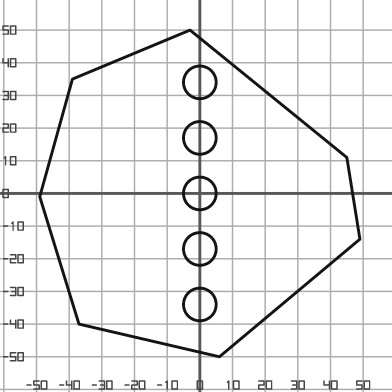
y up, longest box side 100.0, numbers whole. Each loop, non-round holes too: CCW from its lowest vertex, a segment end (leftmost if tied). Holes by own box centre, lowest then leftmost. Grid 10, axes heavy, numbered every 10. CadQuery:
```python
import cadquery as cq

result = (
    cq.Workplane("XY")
    .moveTo(6.0, -50.0)
    .lineTo(49.0, -14.0)
    .lineTo(45.0, 11.0)
    .lineTo(-3.0, 50.0)
    .lineTo(-39.0, 35.0)
    .lineTo(-49.0, -1.0)
    .lineTo(-37.0, -40.0)
    .close()
    .moveTo(0.0, -34.0)
    .circle(5.0)
    .moveTo(0.0, -17.0)
    .circle(5.0)
    .moveTo(0.0, 0.0)
    .circle(5.0)
    .moveTo(0.0, 17.0)
    .circle(5.0)
    .moveTo(0.0, 34.0)
    .circle(5.0)
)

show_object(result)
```